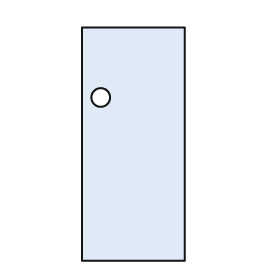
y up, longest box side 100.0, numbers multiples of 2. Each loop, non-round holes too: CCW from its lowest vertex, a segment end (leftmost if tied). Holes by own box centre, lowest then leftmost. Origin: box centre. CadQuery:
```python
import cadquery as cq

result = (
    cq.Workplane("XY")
    .moveTo(-22.0, -50.0)
    .lineTo(22.0, -50.0)
    .lineTo(22.0, 50.0)
    .lineTo(-22.0, 50.0)
    .close()
    .moveTo(-14.0, 20.0)
    .circle(4.0)
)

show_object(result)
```